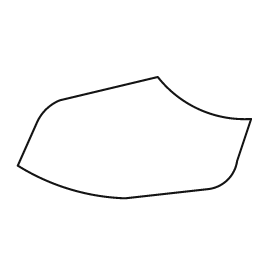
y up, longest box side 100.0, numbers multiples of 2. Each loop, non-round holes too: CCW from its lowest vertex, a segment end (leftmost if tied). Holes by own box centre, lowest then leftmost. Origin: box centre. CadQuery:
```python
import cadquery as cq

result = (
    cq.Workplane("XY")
    .moveTo(-4.0, -26.0)
    .lineTo(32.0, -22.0)
    .threePointArc((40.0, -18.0), (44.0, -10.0))
    .lineTo(50.0, 8.0)
    .threePointArc((28.0, 12.0), (10.0, 26.0))
    .lineTo(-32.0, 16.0)
    .threePointArc((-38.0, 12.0), (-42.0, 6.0))
    .lineTo(-50.0, -12.0)
    .threePointArc((-28.0, -22.0), (-4.0, -26.0))
    .close()
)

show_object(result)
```